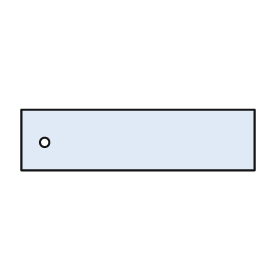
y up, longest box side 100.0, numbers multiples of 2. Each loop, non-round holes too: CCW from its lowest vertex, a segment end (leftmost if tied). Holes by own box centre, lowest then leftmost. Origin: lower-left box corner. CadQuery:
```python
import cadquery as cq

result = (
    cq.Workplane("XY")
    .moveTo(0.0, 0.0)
    .lineTo(100.0, 0.0)
    .lineTo(100.0, 26.0)
    .lineTo(0.0, 26.0)
    .close()
    .moveTo(10.0, 12.0)
    .circle(2.0)
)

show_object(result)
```